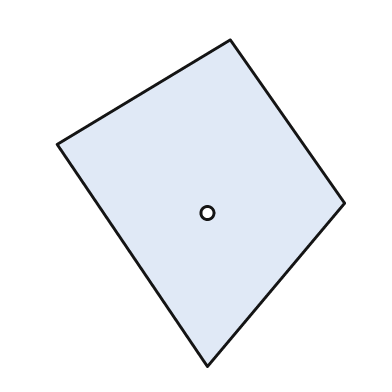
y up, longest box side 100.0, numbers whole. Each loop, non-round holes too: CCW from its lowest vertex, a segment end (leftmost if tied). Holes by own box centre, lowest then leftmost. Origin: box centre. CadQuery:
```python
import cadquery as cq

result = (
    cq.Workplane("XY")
    .moveTo(2.0, -50.0)
    .lineTo(44.0, 0.0)
    .lineTo(9.0, 50.0)
    .lineTo(-44.0, 18.0)
    .close()
    .moveTo(2.0, -3.0)
    .circle(2.0)
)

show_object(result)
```